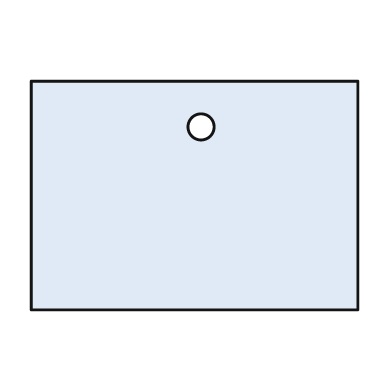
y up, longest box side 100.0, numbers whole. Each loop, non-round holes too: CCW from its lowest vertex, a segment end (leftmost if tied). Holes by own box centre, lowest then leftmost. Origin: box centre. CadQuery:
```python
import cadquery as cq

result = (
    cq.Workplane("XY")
    .moveTo(-50.0, -35.0)
    .lineTo(50.0, -35.0)
    .lineTo(50.0, 35.0)
    .lineTo(-50.0, 35.0)
    .close()
    .moveTo(2.0, 21.0)
    .circle(4.0)
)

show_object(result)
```